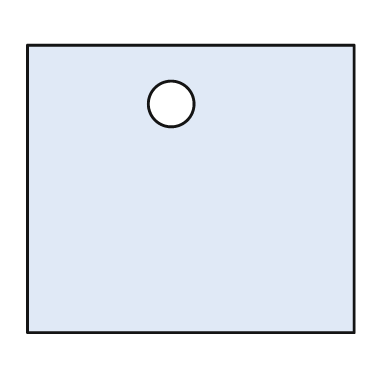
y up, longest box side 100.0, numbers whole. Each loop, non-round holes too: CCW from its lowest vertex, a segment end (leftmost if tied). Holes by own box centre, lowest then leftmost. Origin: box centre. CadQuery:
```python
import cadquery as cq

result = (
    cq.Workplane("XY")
    .moveTo(-50.0, -44.0)
    .lineTo(50.0, -44.0)
    .lineTo(50.0, 44.0)
    .lineTo(-50.0, 44.0)
    .close()
    .moveTo(-6.0, 26.0)
    .circle(7.0)
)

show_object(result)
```